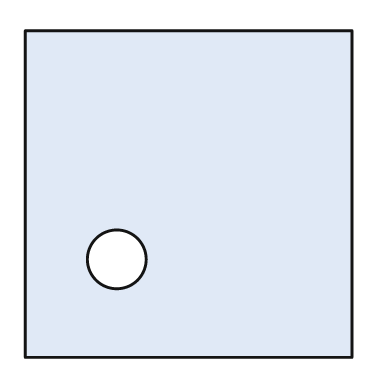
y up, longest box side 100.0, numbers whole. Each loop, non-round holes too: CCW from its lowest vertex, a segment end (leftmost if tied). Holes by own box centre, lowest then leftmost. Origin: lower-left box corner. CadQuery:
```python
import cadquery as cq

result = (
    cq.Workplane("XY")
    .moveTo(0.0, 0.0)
    .lineTo(100.0, 0.0)
    .lineTo(100.0, 100.0)
    .lineTo(0.0, 100.0)
    .close()
    .moveTo(28.0, 30.0)
    .circle(9.0)
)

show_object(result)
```